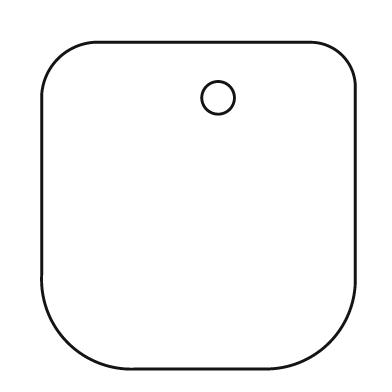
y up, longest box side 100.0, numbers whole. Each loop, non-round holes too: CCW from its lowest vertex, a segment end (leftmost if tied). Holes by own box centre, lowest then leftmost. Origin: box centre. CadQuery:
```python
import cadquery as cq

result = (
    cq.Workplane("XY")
    .moveTo(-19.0, -50.0)
    .lineTo(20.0, -50.0)
    .threePointArc((40.0, -42.0), (48.0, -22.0))
    .lineTo(48.0, 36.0)
    .threePointArc((44.0, 46.0), (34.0, 50.0))
    .lineTo(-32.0, 50.0)
    .threePointArc((-43.0, 45.0), (-48.0, 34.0))
    .lineTo(-48.0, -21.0)
    .threePointArc((-40.0, -42.0), (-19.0, -50.0))
    .close()
    .moveTo(6.0, 33.0)
    .circle(5.0)
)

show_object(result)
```